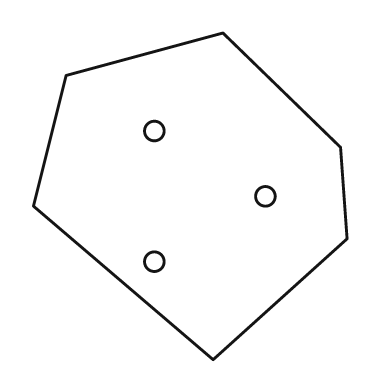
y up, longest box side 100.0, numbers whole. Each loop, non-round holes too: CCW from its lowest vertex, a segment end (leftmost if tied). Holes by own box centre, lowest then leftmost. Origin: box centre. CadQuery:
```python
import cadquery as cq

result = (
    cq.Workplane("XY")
    .moveTo(7.0, -50.0)
    .lineTo(48.0, -13.0)
    .lineTo(46.0, 15.0)
    .lineTo(10.0, 50.0)
    .lineTo(-38.0, 37.0)
    .lineTo(-48.0, -3.0)
    .close()
    .moveTo(-11.0, -20.0)
    .circle(3.0)
    .moveTo(23.0, 0.0)
    .circle(3.0)
    .moveTo(-11.0, 20.0)
    .circle(3.0)
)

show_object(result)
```